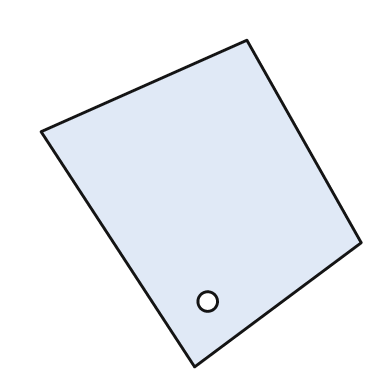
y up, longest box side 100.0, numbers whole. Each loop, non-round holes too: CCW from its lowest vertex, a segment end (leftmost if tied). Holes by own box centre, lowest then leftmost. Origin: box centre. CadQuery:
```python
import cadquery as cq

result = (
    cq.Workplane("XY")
    .moveTo(-2.0, -50.0)
    .lineTo(49.0, -12.0)
    .lineTo(14.0, 50.0)
    .lineTo(-49.0, 22.0)
    .close()
    .moveTo(2.0, -30.0)
    .circle(3.0)
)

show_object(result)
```